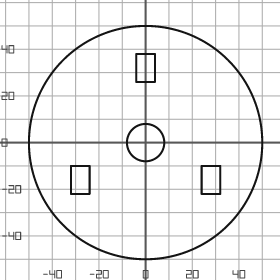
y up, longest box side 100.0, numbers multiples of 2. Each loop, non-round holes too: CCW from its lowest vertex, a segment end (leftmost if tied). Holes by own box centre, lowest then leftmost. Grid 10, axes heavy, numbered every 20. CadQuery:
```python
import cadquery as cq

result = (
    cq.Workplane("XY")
    .moveTo(0.0, 0.0)
    .circle(50.0)
    .moveTo(-32.0, -22.0)
    .lineTo(-24.0, -22.0)
    .lineTo(-24.0, -10.0)
    .lineTo(-32.0, -10.0)
    .close()
    .moveTo(24.0, -22.0)
    .lineTo(32.0, -22.0)
    .lineTo(32.0, -10.0)
    .lineTo(24.0, -10.0)
    .close()
    .moveTo(0.0, 0.0)
    .circle(8.0)
    .moveTo(-4.0, 26.0)
    .lineTo(4.0, 26.0)
    .lineTo(4.0, 38.0)
    .lineTo(-4.0, 38.0)
    .close()
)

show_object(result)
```